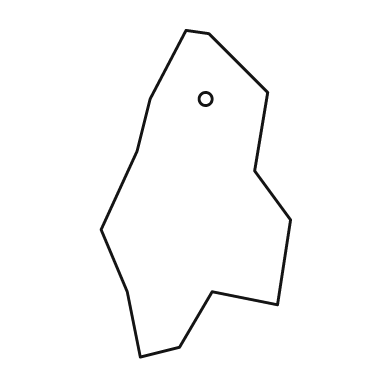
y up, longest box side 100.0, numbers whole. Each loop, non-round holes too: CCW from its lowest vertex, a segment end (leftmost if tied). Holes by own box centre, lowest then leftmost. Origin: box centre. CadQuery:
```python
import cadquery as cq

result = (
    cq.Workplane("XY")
    .moveTo(-17.0, -50.0)
    .lineTo(-5.0, -47.0)
    .lineTo(5.0, -30.0)
    .lineTo(25.0, -34.0)
    .lineTo(29.0, -8.0)
    .lineTo(18.0, 7.0)
    .lineTo(22.0, 31.0)
    .lineTo(4.0, 49.0)
    .lineTo(-3.0, 50.0)
    .lineTo(-14.0, 29.0)
    .lineTo(-18.0, 13.0)
    .lineTo(-29.0, -11.0)
    .lineTo(-21.0, -30.0)
    .close()
    .moveTo(3.0, 29.0)
    .circle(2.0)
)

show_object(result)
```